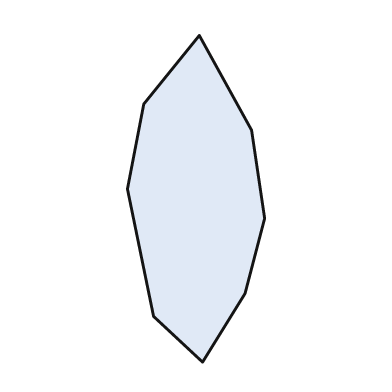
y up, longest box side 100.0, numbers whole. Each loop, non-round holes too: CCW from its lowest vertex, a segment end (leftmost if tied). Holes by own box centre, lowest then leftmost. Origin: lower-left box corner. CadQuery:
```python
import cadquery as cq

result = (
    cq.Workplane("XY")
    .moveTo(23.0, 0.0)
    .lineTo(36.0, 21.0)
    .lineTo(42.0, 44.0)
    .lineTo(38.0, 71.0)
    .lineTo(22.0, 100.0)
    .lineTo(5.0, 79.0)
    .lineTo(0.0, 53.0)
    .lineTo(8.0, 14.0)
    .close()
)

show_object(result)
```